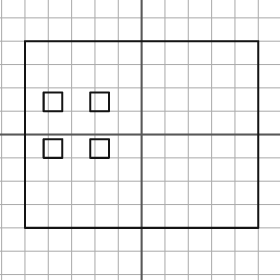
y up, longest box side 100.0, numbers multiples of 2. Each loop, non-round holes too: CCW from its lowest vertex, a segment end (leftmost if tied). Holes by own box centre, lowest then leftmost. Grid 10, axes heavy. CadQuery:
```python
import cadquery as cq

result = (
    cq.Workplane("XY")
    .moveTo(-50.0, -40.0)
    .lineTo(50.0, -40.0)
    .lineTo(50.0, 40.0)
    .lineTo(-50.0, 40.0)
    .close()
    .moveTo(-42.0, -10.0)
    .lineTo(-34.0, -10.0)
    .lineTo(-34.0, -2.0)
    .lineTo(-42.0, -2.0)
    .close()
    .moveTo(-22.0, -10.0)
    .lineTo(-14.0, -10.0)
    .lineTo(-14.0, -2.0)
    .lineTo(-22.0, -2.0)
    .close()
    .moveTo(-42.0, 10.0)
    .lineTo(-34.0, 10.0)
    .lineTo(-34.0, 18.0)
    .lineTo(-42.0, 18.0)
    .close()
    .moveTo(-22.0, 10.0)
    .lineTo(-14.0, 10.0)
    .lineTo(-14.0, 18.0)
    .lineTo(-22.0, 18.0)
    .close()
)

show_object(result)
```